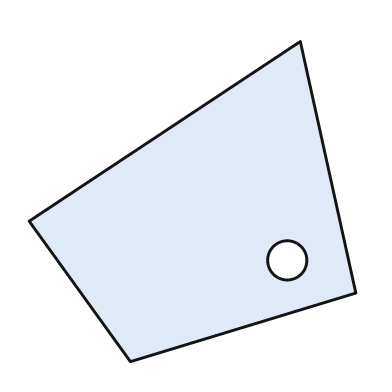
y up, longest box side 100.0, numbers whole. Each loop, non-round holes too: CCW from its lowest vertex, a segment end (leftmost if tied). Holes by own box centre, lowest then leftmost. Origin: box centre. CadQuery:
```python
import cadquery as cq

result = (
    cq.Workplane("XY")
    .moveTo(-19.0, -49.0)
    .lineTo(50.0, -28.0)
    .lineTo(33.0, 49.0)
    .lineTo(-50.0, -6.0)
    .close()
    .moveTo(29.0, -18.0)
    .circle(6.0)
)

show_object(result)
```